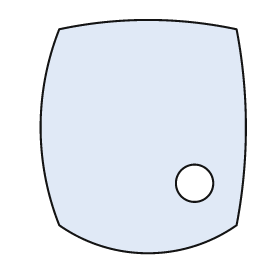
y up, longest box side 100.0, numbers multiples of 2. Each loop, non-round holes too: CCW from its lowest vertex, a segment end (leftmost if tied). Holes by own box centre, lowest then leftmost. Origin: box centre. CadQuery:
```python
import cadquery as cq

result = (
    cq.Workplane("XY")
    .moveTo(-36.0, -38.0)
    .threePointArc((2.0, -50.0), (40.0, -38.0))
    .threePointArc((44.0, 4.0), (40.0, 46.0))
    .threePointArc((2.0, 50.0), (-36.0, 46.0))
    .threePointArc((-44.0, 4.0), (-36.0, -38.0))
    .close()
    .moveTo(22.0, -20.0)
    .circle(8.0)
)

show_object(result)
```